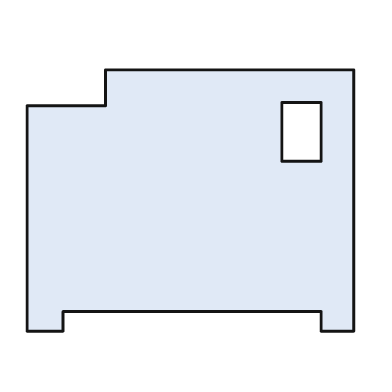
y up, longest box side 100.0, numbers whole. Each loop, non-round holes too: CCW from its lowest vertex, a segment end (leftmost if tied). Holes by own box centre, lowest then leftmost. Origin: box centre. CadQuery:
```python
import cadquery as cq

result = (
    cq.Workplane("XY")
    .moveTo(-50.0, -40.0)
    .lineTo(-39.0, -40.0)
    .lineTo(-39.0, -34.0)
    .lineTo(40.0, -34.0)
    .lineTo(40.0, -40.0)
    .lineTo(50.0, -40.0)
    .lineTo(50.0, 40.0)
    .lineTo(-26.0, 40.0)
    .lineTo(-26.0, 29.0)
    .lineTo(-50.0, 29.0)
    .close()
    .moveTo(28.0, 12.0)
    .lineTo(40.0, 12.0)
    .lineTo(40.0, 30.0)
    .lineTo(28.0, 30.0)
    .close()
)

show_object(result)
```